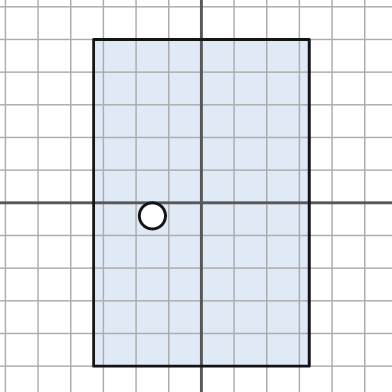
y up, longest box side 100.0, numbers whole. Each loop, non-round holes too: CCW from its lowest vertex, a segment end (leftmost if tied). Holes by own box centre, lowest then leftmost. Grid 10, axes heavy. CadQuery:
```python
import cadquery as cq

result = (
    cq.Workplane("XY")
    .moveTo(-33.0, -50.0)
    .lineTo(33.0, -50.0)
    .lineTo(33.0, 50.0)
    .lineTo(-33.0, 50.0)
    .close()
    .moveTo(-15.0, -4.0)
    .circle(4.0)
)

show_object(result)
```